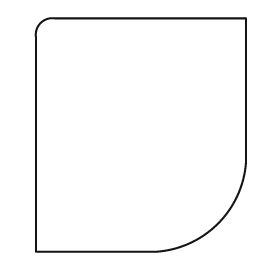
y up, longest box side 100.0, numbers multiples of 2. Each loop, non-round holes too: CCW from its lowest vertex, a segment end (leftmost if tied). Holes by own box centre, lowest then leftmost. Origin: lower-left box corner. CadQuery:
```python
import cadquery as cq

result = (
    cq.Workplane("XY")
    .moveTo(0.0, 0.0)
    .lineTo(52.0, 0.0)
    .threePointArc((78.0, 12.0), (90.0, 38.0))
    .lineTo(90.0, 100.0)
    .lineTo(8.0, 100.0)
    .threePointArc((2.0, 98.0), (0.0, 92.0))
    .close()
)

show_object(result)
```